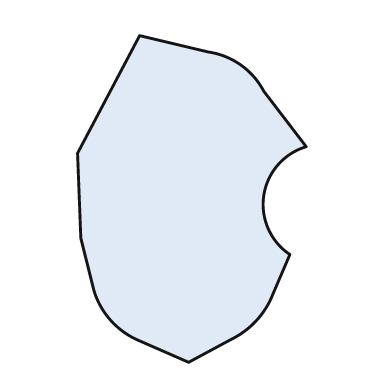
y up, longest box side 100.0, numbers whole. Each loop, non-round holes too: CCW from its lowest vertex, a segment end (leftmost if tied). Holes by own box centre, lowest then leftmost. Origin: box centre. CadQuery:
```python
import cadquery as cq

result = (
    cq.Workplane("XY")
    .moveTo(-1.0, -50.0)
    .lineTo(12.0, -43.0)
    .threePointArc((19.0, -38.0), (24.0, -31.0))
    .lineTo(30.0, -17.0)
    .threePointArc((22.0, 1.0), (35.0, 16.0))
    .lineTo(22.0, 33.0)
    .threePointArc((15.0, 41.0), (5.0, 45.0))
    .lineTo(-16.0, 50.0)
    .lineTo(-35.0, 14.0)
    .lineTo(-34.0, -12.0)
    .lineTo(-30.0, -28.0)
    .threePointArc((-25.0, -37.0), (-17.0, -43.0))
    .close()
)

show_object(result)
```